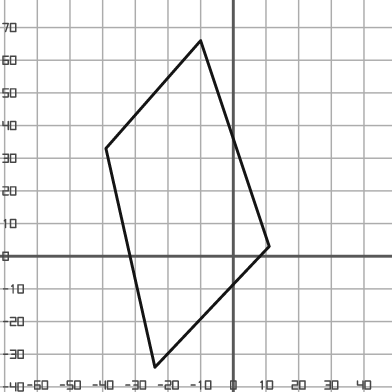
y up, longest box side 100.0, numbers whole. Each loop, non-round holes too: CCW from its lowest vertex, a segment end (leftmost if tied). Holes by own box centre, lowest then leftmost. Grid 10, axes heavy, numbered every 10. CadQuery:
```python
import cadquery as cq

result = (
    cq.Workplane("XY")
    .moveTo(-24.0, -34.0)
    .lineTo(11.0, 3.0)
    .lineTo(-10.0, 66.0)
    .lineTo(-39.0, 33.0)
    .close()
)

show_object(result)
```